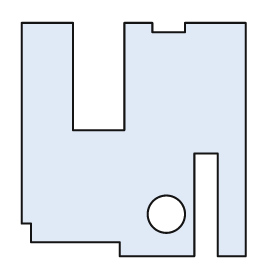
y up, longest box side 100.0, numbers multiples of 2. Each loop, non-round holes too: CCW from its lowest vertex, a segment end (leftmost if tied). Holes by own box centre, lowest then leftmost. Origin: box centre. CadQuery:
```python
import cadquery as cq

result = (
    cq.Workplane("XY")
    .moveTo(-6.0, -50.0)
    .lineTo(26.0, -50.0)
    .lineTo(26.0, -6.0)
    .lineTo(36.0, -6.0)
    .lineTo(36.0, -50.0)
    .lineTo(48.0, -50.0)
    .lineTo(48.0, 50.0)
    .lineTo(22.0, 50.0)
    .lineTo(22.0, 46.0)
    .lineTo(8.0, 46.0)
    .lineTo(8.0, 50.0)
    .lineTo(-4.0, 50.0)
    .lineTo(-4.0, 4.0)
    .lineTo(-26.0, 4.0)
    .lineTo(-26.0, 50.0)
    .lineTo(-48.0, 50.0)
    .lineTo(-48.0, -36.0)
    .lineTo(-44.0, -36.0)
    .lineTo(-44.0, -44.0)
    .lineTo(-6.0, -44.0)
    .close()
    .moveTo(14.0, -32.0)
    .circle(8.0)
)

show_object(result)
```